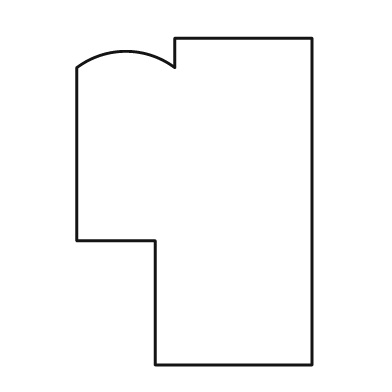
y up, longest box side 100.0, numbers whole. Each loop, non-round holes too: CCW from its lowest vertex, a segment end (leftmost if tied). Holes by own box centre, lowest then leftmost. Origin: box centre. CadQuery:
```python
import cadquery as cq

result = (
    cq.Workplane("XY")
    .moveTo(-12.0, -50.0)
    .lineTo(36.0, -50.0)
    .lineTo(36.0, 50.0)
    .lineTo(-6.0, 50.0)
    .lineTo(-6.0, 41.0)
    .threePointArc((-21.0, 46.0), (-36.0, 41.0))
    .lineTo(-36.0, -12.0)
    .lineTo(-12.0, -12.0)
    .close()
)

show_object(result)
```